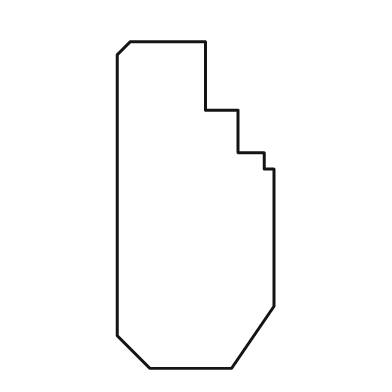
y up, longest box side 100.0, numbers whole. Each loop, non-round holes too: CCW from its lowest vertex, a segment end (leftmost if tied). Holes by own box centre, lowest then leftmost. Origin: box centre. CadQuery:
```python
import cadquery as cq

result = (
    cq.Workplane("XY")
    .moveTo(-14.0, -50.0)
    .lineTo(11.0, -50.0)
    .lineTo(24.0, -31.0)
    .lineTo(24.0, 11.0)
    .lineTo(21.0, 11.0)
    .lineTo(21.0, 16.0)
    .lineTo(13.0, 16.0)
    .lineTo(13.0, 29.0)
    .lineTo(3.0, 29.0)
    .lineTo(3.0, 50.0)
    .lineTo(-20.0, 50.0)
    .lineTo(-24.0, 46.0)
    .lineTo(-24.0, -40.0)
    .close()
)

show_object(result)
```